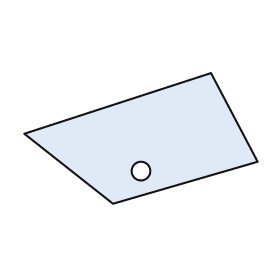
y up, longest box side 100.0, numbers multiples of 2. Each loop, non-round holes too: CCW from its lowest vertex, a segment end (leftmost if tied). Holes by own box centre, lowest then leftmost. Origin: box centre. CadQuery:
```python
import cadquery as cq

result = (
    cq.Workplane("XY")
    .moveTo(-12.0, -28.0)
    .lineTo(50.0, -10.0)
    .lineTo(30.0, 28.0)
    .lineTo(-50.0, 2.0)
    .close()
    .moveTo(0.0, -14.0)
    .circle(4.0)
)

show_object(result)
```